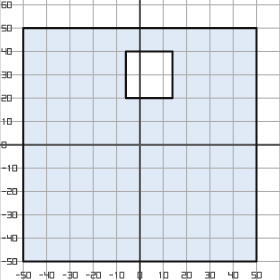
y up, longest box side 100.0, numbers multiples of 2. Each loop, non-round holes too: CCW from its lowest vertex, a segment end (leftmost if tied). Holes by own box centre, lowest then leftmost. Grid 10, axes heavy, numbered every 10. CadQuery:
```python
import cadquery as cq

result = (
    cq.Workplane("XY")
    .moveTo(-50.0, -50.0)
    .lineTo(50.0, -50.0)
    .lineTo(50.0, 50.0)
    .lineTo(-50.0, 50.0)
    .close()
    .moveTo(-6.0, 20.0)
    .lineTo(14.0, 20.0)
    .lineTo(14.0, 40.0)
    .lineTo(-6.0, 40.0)
    .close()
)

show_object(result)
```